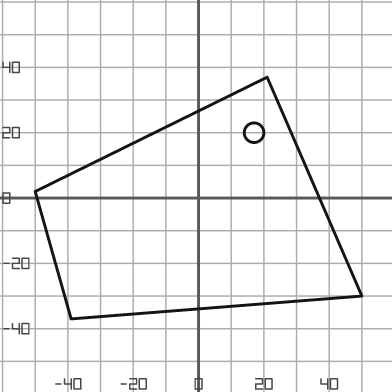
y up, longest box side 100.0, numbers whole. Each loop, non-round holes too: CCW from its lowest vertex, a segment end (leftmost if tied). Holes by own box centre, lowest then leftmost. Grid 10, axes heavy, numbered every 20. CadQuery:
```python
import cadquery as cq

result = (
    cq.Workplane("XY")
    .moveTo(-39.0, -37.0)
    .lineTo(50.0, -30.0)
    .lineTo(21.0, 37.0)
    .lineTo(-50.0, 2.0)
    .close()
    .moveTo(17.0, 20.0)
    .circle(3.0)
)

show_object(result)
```